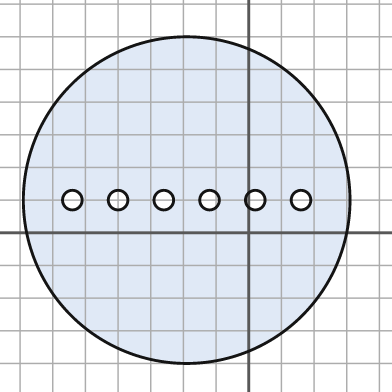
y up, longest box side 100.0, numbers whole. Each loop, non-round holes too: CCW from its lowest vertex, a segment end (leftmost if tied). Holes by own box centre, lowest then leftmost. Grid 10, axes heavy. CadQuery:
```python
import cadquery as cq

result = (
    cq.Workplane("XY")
    .moveTo(-19.0, 10.0)
    .circle(50.0)
    .moveTo(-54.0, 10.0)
    .circle(3.0)
    .moveTo(-40.0, 10.0)
    .circle(3.0)
    .moveTo(-26.0, 10.0)
    .circle(3.0)
    .moveTo(-12.0, 10.0)
    .circle(3.0)
    .moveTo(2.0, 10.0)
    .circle(3.0)
    .moveTo(16.0, 10.0)
    .circle(3.0)
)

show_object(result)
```